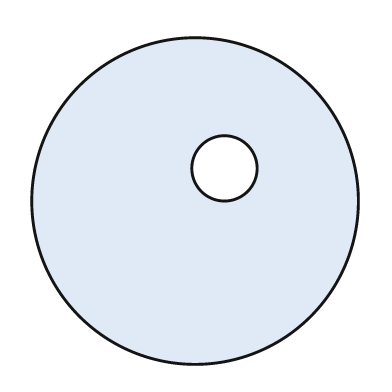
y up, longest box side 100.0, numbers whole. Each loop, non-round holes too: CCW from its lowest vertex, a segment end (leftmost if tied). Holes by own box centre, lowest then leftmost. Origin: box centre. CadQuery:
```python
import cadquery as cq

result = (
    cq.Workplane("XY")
    .moveTo(0.0, 0.0)
    .circle(50.0)
    .moveTo(9.0, 10.0)
    .circle(10.0)
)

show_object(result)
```